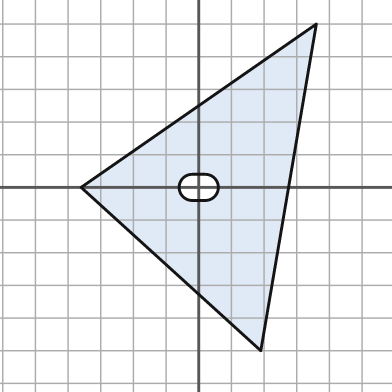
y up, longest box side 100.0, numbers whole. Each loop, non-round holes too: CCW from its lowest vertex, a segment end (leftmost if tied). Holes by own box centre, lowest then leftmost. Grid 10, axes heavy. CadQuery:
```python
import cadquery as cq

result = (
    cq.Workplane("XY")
    .moveTo(19.0, -50.0)
    .lineTo(36.0, 50.0)
    .lineTo(-36.0, 0.0)
    .close()
    .moveTo(-2.0, -4.0)
    .lineTo(2.0, -4.0)
    .threePointArc((6.0, 0.0), (2.0, 4.0))
    .lineTo(-2.0, 4.0)
    .threePointArc((-6.0, 0.0), (-2.0, -4.0))
    .close()
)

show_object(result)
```